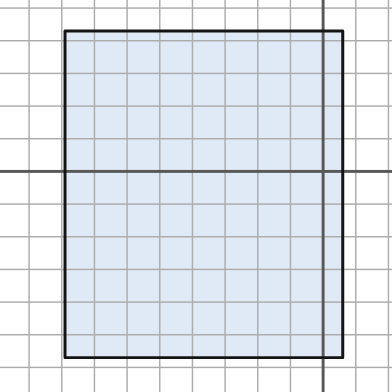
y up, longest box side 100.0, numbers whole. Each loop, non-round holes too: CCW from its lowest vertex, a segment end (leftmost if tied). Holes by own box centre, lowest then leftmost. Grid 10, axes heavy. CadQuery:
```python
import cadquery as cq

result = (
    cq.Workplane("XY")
    .moveTo(-79.0, -57.0)
    .lineTo(6.0, -57.0)
    .lineTo(6.0, 43.0)
    .lineTo(-79.0, 43.0)
    .close()
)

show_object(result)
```